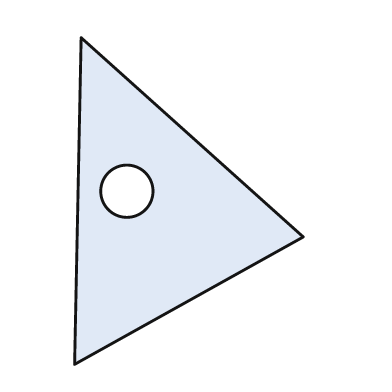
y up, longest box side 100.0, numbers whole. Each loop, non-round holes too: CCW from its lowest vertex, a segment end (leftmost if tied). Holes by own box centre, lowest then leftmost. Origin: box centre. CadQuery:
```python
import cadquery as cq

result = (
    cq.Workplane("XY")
    .moveTo(-35.0, -50.0)
    .lineTo(35.0, -11.0)
    .lineTo(-33.0, 50.0)
    .close()
    .moveTo(-19.0, 3.0)
    .circle(8.0)
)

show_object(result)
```